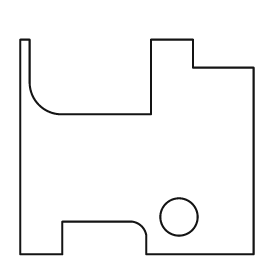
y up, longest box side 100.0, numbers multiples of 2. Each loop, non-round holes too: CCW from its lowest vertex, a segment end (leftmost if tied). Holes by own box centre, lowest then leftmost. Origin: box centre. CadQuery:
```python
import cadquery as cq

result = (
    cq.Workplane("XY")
    .moveTo(-50.0, -46.0)
    .lineTo(-32.0, -46.0)
    .lineTo(-32.0, -32.0)
    .lineTo(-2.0, -32.0)
    .threePointArc((2.0, -34.0), (4.0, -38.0))
    .lineTo(4.0, -46.0)
    .lineTo(50.0, -46.0)
    .lineTo(50.0, 34.0)
    .lineTo(24.0, 34.0)
    .lineTo(24.0, 46.0)
    .lineTo(6.0, 46.0)
    .lineTo(6.0, 14.0)
    .lineTo(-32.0, 14.0)
    .threePointArc((-42.0, 18.0), (-46.0, 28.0))
    .lineTo(-46.0, 46.0)
    .lineTo(-50.0, 46.0)
    .close()
    .moveTo(18.0, -30.0)
    .circle(8.0)
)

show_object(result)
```